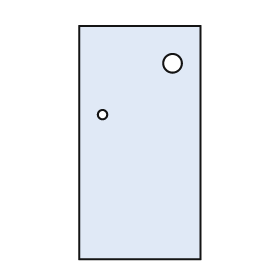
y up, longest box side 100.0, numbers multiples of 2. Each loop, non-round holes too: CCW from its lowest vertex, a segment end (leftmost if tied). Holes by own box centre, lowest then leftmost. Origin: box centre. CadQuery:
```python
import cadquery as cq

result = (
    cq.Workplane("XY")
    .moveTo(-26.0, -50.0)
    .lineTo(26.0, -50.0)
    .lineTo(26.0, 50.0)
    .lineTo(-26.0, 50.0)
    .close()
    .moveTo(-16.0, 12.0)
    .circle(2.0)
    .moveTo(14.0, 34.0)
    .circle(4.0)
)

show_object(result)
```